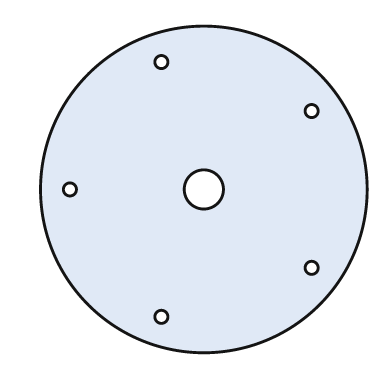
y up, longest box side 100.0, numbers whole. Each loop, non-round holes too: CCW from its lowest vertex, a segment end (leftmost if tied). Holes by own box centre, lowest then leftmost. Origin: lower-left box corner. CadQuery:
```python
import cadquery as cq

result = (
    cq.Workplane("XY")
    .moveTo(50.0, 50.0)
    .circle(50.0)
    .moveTo(37.0, 11.0)
    .circle(2.0)
    .moveTo(83.0, 26.0)
    .circle(2.0)
    .moveTo(9.0, 50.0)
    .circle(2.0)
    .moveTo(50.0, 50.0)
    .circle(6.0)
    .moveTo(83.0, 74.0)
    .circle(2.0)
    .moveTo(37.0, 89.0)
    .circle(2.0)
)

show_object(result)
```